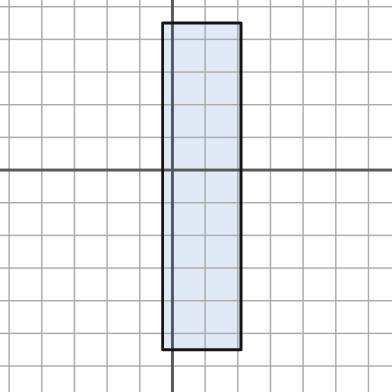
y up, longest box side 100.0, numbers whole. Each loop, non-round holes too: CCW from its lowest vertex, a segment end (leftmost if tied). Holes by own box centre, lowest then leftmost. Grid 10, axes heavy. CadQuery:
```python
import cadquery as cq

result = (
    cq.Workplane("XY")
    .moveTo(-3.0, -55.0)
    .lineTo(21.0, -55.0)
    .lineTo(21.0, 45.0)
    .lineTo(-3.0, 45.0)
    .close()
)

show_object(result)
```